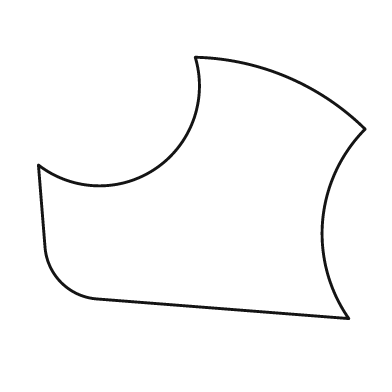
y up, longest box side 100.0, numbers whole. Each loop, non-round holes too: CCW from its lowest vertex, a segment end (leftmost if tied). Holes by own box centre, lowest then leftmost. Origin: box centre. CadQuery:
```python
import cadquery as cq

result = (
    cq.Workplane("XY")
    .moveTo(45.0, -40.0)
    .threePointArc((37.0, -10.0), (50.0, 18.0))
    .threePointArc((26.0, 34.0), (-2.0, 40.0))
    .threePointArc((-14.0, 6.0), (-50.0, 7.0))
    .lineTo(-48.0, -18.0)
    .threePointArc((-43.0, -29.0), (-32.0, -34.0))
    .close()
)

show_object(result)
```